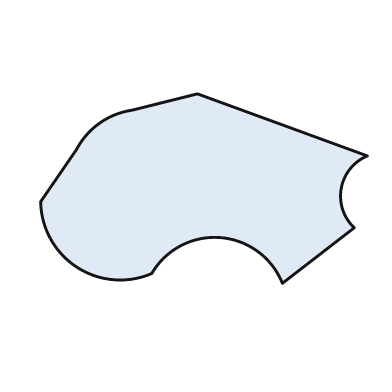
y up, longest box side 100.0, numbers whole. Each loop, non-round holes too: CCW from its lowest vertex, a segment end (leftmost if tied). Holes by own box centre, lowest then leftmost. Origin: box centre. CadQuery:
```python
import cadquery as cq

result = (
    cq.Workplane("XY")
    .moveTo(24.0, -29.0)
    .lineTo(46.0, -12.0)
    .threePointArc((42.0, 0.0), (50.0, 10.0))
    .lineTo(-2.0, 29.0)
    .lineTo(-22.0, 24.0)
    .threePointArc((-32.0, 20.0), (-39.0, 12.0))
    .lineTo(-50.0, -4.0)
    .threePointArc((-39.0, -24.0), (-16.0, -26.0))
    .threePointArc((5.0, -15.0), (24.0, -29.0))
    .close()
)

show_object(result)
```